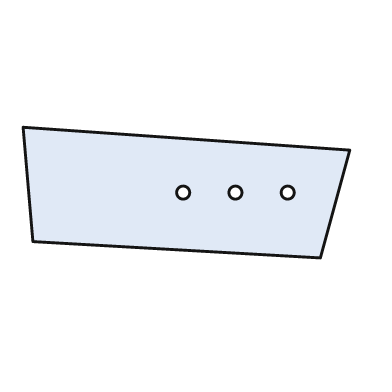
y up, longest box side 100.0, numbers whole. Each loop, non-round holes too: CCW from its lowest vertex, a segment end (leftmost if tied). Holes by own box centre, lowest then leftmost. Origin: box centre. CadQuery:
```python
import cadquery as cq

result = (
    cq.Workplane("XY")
    .moveTo(41.0, -20.0)
    .lineTo(50.0, 13.0)
    .lineTo(-50.0, 20.0)
    .lineTo(-47.0, -15.0)
    .close()
    .moveTo(-1.0, 0.0)
    .circle(2.0)
    .moveTo(15.0, 0.0)
    .circle(2.0)
    .moveTo(31.0, 0.0)
    .circle(2.0)
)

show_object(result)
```